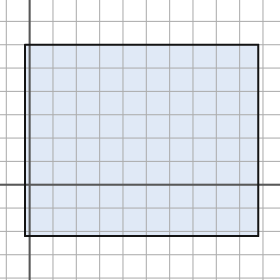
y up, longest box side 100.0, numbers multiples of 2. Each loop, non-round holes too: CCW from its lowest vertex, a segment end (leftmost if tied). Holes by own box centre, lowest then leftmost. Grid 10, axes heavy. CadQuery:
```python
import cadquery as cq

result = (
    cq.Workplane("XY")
    .moveTo(-2.0, -22.0)
    .lineTo(98.0, -22.0)
    .lineTo(98.0, 60.0)
    .lineTo(-2.0, 60.0)
    .close()
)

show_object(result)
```